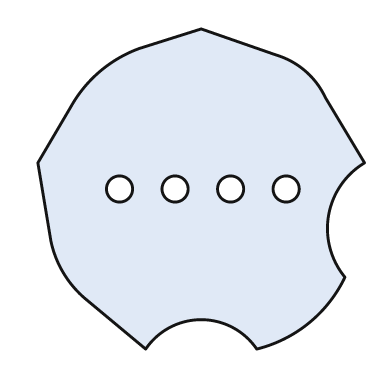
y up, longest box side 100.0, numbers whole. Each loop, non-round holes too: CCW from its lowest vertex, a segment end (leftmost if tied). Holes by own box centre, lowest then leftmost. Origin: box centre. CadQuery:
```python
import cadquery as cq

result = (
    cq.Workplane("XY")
    .moveTo(-17.0, -49.0)
    .threePointArc((0.0, -40.0), (17.0, -49.0))
    .threePointArc((33.0, -41.0), (44.0, -27.0))
    .threePointArc((39.0, -8.0), (50.0, 8.0))
    .lineTo(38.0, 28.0)
    .threePointArc((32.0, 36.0), (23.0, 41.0))
    .lineTo(0.0, 49.0)
    .lineTo(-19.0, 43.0)
    .threePointArc((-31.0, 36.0), (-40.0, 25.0))
    .lineTo(-50.0, 8.0)
    .lineTo(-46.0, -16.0)
    .threePointArc((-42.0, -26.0), (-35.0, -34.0))
    .close()
    .moveTo(-25.0, 0.0)
    .circle(4.0)
    .moveTo(-8.0, 0.0)
    .circle(4.0)
    .moveTo(9.0, 0.0)
    .circle(4.0)
    .moveTo(26.0, 0.0)
    .circle(4.0)
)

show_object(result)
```